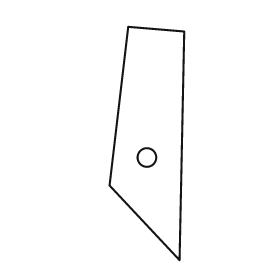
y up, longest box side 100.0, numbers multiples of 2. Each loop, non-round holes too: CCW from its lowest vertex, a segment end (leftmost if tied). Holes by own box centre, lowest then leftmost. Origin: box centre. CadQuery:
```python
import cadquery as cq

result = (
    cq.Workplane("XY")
    .moveTo(14.0, -50.0)
    .lineTo(16.0, 48.0)
    .lineTo(-8.0, 50.0)
    .lineTo(-16.0, -18.0)
    .close()
    .moveTo(0.0, -6.0)
    .circle(4.0)
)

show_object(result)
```